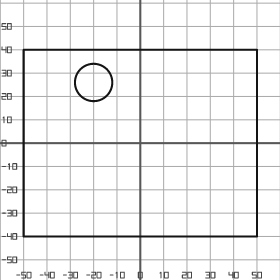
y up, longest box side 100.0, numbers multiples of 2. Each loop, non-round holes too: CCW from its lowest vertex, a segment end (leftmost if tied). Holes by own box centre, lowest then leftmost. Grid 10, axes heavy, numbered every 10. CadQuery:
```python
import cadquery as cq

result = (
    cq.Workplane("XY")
    .moveTo(-50.0, -40.0)
    .lineTo(50.0, -40.0)
    .lineTo(50.0, 40.0)
    .lineTo(-50.0, 40.0)
    .close()
    .moveTo(-20.0, 26.0)
    .circle(8.0)
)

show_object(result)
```